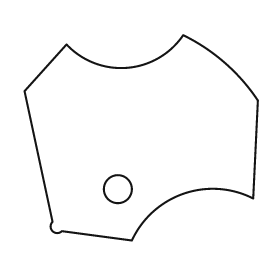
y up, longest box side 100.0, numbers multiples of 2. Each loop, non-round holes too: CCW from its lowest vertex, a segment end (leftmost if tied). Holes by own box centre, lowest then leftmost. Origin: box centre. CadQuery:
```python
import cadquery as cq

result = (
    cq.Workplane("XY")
    .moveTo(-4.0, -44.0)
    .threePointArc((18.0, -24.0), (48.0, -26.0))
    .lineTo(50.0, 16.0)
    .threePointArc((36.0, 32.0), (18.0, 44.0))
    .threePointArc((-6.0, 30.0), (-32.0, 40.0))
    .lineTo(-50.0, 20.0)
    .lineTo(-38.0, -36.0)
    .threePointArc((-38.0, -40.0), (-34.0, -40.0))
    .close()
    .moveTo(-10.0, -22.0)
    .circle(6.0)
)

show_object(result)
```